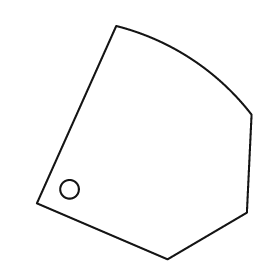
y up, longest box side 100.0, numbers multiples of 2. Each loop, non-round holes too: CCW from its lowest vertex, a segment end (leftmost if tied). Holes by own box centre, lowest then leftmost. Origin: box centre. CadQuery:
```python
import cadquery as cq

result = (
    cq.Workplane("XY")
    .moveTo(10.0, -50.0)
    .lineTo(44.0, -30.0)
    .lineTo(46.0, 12.0)
    .threePointArc((20.0, 36.0), (-12.0, 50.0))
    .lineTo(-46.0, -26.0)
    .close()
    .moveTo(-32.0, -20.0)
    .circle(4.0)
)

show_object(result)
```